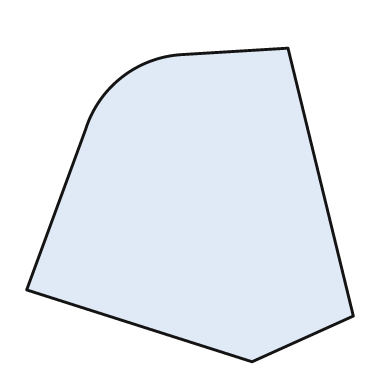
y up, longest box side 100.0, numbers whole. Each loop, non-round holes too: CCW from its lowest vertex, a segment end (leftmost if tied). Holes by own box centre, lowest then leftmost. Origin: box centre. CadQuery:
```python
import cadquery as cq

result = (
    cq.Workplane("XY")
    .moveTo(19.0, -48.0)
    .lineTo(50.0, -34.0)
    .lineTo(30.0, 48.0)
    .lineTo(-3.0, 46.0)
    .threePointArc((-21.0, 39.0), (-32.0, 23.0))
    .lineTo(-50.0, -26.0)
    .close()
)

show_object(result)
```